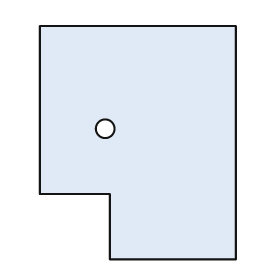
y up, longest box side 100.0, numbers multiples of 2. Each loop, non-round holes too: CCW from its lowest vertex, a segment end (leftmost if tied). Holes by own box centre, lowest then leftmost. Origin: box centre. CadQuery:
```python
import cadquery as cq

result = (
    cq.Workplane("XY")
    .moveTo(-12.0, -50.0)
    .lineTo(42.0, -50.0)
    .lineTo(42.0, 50.0)
    .lineTo(-42.0, 50.0)
    .lineTo(-42.0, -22.0)
    .lineTo(-12.0, -22.0)
    .close()
    .moveTo(-14.0, 6.0)
    .circle(4.0)
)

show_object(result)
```